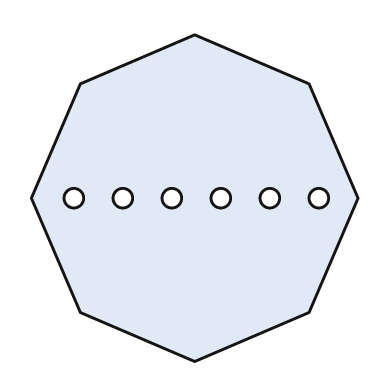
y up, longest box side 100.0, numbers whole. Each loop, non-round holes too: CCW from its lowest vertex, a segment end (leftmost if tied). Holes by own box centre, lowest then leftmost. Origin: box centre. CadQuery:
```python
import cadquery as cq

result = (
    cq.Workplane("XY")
    .moveTo(0.0, -50.0)
    .lineTo(35.0, -35.0)
    .lineTo(50.0, 0.0)
    .lineTo(35.0, 35.0)
    .lineTo(0.0, 50.0)
    .lineTo(-35.0, 35.0)
    .lineTo(-50.0, 0.0)
    .lineTo(-35.0, -35.0)
    .close()
    .moveTo(-37.0, 0.0)
    .circle(3.0)
    .moveTo(-22.0, 0.0)
    .circle(3.0)
    .moveTo(-7.0, 0.0)
    .circle(3.0)
    .moveTo(8.0, 0.0)
    .circle(3.0)
    .moveTo(23.0, 0.0)
    .circle(3.0)
    .moveTo(38.0, 0.0)
    .circle(3.0)
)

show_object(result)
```